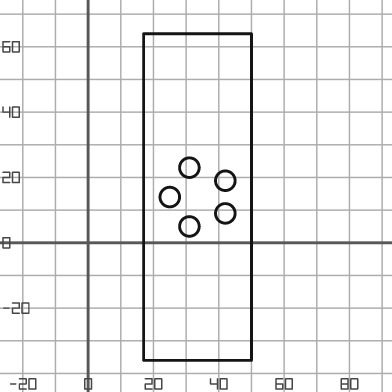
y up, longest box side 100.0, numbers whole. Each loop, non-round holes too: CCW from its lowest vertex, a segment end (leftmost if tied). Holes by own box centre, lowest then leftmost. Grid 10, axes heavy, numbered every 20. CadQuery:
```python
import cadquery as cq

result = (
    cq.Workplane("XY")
    .moveTo(17.0, -36.0)
    .lineTo(50.0, -36.0)
    .lineTo(50.0, 64.0)
    .lineTo(17.0, 64.0)
    .close()
    .moveTo(31.0, 5.0)
    .circle(3.0)
    .moveTo(42.0, 9.0)
    .circle(3.0)
    .moveTo(25.0, 14.0)
    .circle(3.0)
    .moveTo(42.0, 19.0)
    .circle(3.0)
    .moveTo(31.0, 23.0)
    .circle(3.0)
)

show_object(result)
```